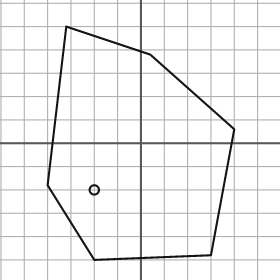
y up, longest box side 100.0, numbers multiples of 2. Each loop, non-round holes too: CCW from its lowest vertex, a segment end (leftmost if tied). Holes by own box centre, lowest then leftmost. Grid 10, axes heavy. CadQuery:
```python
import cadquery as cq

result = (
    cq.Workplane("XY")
    .moveTo(-20.0, -50.0)
    .lineTo(30.0, -48.0)
    .lineTo(40.0, 6.0)
    .lineTo(4.0, 38.0)
    .lineTo(-32.0, 50.0)
    .lineTo(-40.0, -18.0)
    .close()
    .moveTo(-20.0, -20.0)
    .circle(2.0)
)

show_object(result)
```